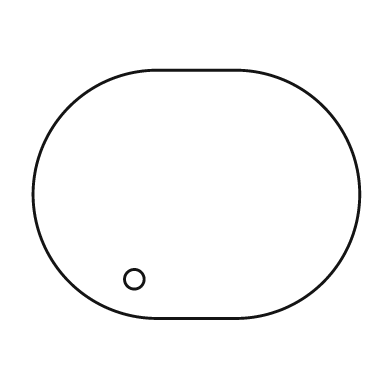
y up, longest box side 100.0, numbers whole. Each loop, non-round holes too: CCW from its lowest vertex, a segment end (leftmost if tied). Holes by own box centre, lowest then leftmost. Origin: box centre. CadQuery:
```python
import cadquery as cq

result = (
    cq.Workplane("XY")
    .moveTo(-12.0, -38.0)
    .lineTo(12.0, -38.0)
    .threePointArc((50.0, 0.0), (12.0, 38.0))
    .lineTo(-12.0, 38.0)
    .threePointArc((-50.0, 0.0), (-12.0, -38.0))
    .close()
    .moveTo(-19.0, -26.0)
    .circle(3.0)
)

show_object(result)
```